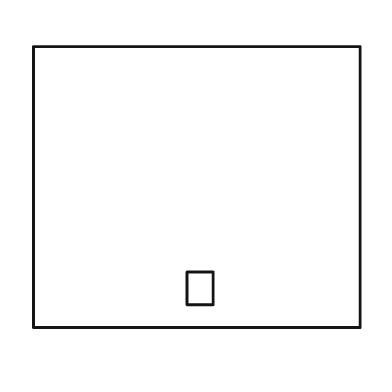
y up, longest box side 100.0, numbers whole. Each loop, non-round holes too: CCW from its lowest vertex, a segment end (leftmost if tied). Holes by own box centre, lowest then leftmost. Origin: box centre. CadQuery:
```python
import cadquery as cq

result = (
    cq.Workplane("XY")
    .moveTo(-50.0, -43.0)
    .lineTo(50.0, -43.0)
    .lineTo(50.0, 43.0)
    .lineTo(-50.0, 43.0)
    .close()
    .moveTo(-3.0, -36.0)
    .lineTo(5.0, -36.0)
    .lineTo(5.0, -26.0)
    .lineTo(-3.0, -26.0)
    .close()
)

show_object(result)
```